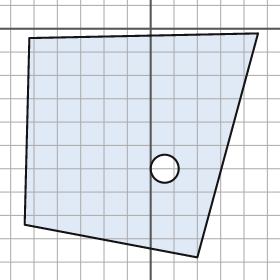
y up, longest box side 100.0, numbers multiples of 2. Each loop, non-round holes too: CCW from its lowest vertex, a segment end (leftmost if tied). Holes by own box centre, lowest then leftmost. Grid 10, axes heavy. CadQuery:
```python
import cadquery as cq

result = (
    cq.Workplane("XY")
    .moveTo(20.0, -98.0)
    .lineTo(46.0, -2.0)
    .lineTo(-52.0, -4.0)
    .lineTo(-54.0, -84.0)
    .close()
    .moveTo(6.0, -60.0)
    .circle(6.0)
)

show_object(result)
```